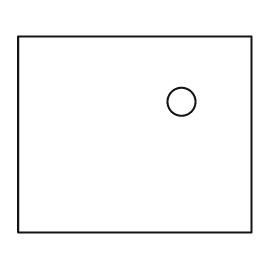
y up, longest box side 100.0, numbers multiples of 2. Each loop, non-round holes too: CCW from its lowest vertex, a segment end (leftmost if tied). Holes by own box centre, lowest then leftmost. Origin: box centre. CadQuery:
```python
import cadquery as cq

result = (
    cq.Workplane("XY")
    .moveTo(-50.0, -42.0)
    .lineTo(50.0, -42.0)
    .lineTo(50.0, 42.0)
    .lineTo(-50.0, 42.0)
    .close()
    .moveTo(20.0, 14.0)
    .circle(6.0)
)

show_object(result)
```